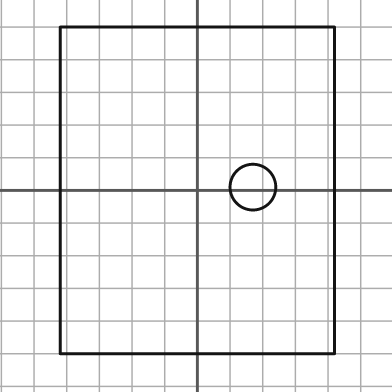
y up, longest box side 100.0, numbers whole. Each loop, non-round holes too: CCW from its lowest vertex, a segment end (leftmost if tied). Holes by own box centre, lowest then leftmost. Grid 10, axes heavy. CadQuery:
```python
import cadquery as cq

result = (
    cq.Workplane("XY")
    .moveTo(-42.0, -50.0)
    .lineTo(42.0, -50.0)
    .lineTo(42.0, 50.0)
    .lineTo(-42.0, 50.0)
    .close()
    .moveTo(17.0, 1.0)
    .circle(7.0)
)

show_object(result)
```